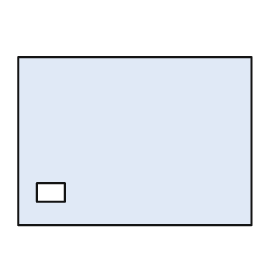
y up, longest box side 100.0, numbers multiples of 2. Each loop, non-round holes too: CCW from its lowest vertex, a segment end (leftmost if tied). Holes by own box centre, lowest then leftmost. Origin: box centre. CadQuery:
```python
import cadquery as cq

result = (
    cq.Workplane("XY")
    .moveTo(-50.0, -36.0)
    .lineTo(50.0, -36.0)
    .lineTo(50.0, 36.0)
    .lineTo(-50.0, 36.0)
    .close()
    .moveTo(-42.0, -26.0)
    .lineTo(-30.0, -26.0)
    .lineTo(-30.0, -18.0)
    .lineTo(-42.0, -18.0)
    .close()
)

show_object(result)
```